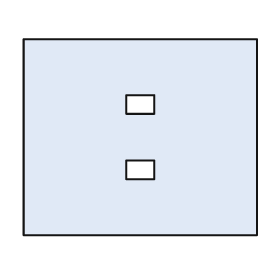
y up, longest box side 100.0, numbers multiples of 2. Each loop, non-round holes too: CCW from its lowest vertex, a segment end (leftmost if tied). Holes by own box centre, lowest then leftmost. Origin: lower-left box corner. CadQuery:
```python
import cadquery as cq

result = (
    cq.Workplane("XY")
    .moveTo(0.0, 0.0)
    .lineTo(100.0, 0.0)
    .lineTo(100.0, 84.0)
    .lineTo(0.0, 84.0)
    .close()
    .moveTo(44.0, 24.0)
    .lineTo(56.0, 24.0)
    .lineTo(56.0, 32.0)
    .lineTo(44.0, 32.0)
    .close()
    .moveTo(44.0, 52.0)
    .lineTo(56.0, 52.0)
    .lineTo(56.0, 60.0)
    .lineTo(44.0, 60.0)
    .close()
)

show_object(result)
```